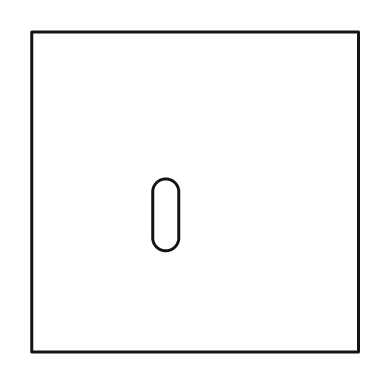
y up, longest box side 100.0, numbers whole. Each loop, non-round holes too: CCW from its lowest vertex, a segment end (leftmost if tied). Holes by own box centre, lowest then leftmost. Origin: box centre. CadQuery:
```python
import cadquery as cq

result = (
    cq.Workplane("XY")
    .moveTo(-50.0, -49.0)
    .lineTo(50.0, -49.0)
    .lineTo(50.0, 49.0)
    .lineTo(-50.0, 49.0)
    .close()
    .moveTo(-13.0, -14.0)
    .threePointArc((-9.0, -18.0), (-5.0, -14.0))
    .lineTo(-5.0, 0.0)
    .threePointArc((-9.0, 4.0), (-13.0, 0.0))
    .close()
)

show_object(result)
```